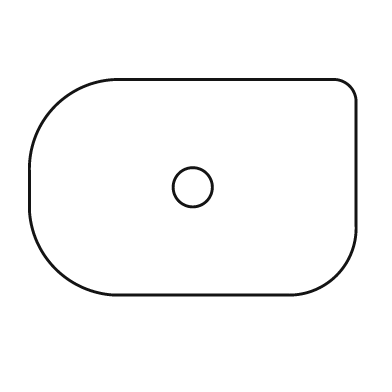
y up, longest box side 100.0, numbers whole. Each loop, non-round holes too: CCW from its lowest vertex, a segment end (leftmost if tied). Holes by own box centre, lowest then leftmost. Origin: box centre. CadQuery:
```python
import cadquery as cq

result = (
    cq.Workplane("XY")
    .moveTo(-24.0, -33.0)
    .lineTo(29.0, -33.0)
    .threePointArc((44.0, -27.0), (50.0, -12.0))
    .lineTo(50.0, 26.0)
    .threePointArc((48.0, 31.0), (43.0, 33.0))
    .lineTo(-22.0, 33.0)
    .threePointArc((-42.0, 25.0), (-50.0, 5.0))
    .lineTo(-50.0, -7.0)
    .threePointArc((-42.0, -25.0), (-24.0, -33.0))
    .close()
    .moveTo(0.0, 0.0)
    .circle(6.0)
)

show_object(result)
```